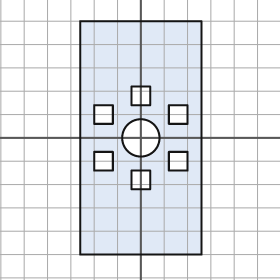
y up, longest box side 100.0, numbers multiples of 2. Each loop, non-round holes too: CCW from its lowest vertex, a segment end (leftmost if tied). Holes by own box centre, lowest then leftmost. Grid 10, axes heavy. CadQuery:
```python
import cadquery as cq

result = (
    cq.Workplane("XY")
    .moveTo(-26.0, -50.0)
    .lineTo(26.0, -50.0)
    .lineTo(26.0, 50.0)
    .lineTo(-26.0, 50.0)
    .close()
    .moveTo(-4.0, -22.0)
    .lineTo(4.0, -22.0)
    .lineTo(4.0, -14.0)
    .lineTo(-4.0, -14.0)
    .close()
    .moveTo(-20.0, -14.0)
    .lineTo(-12.0, -14.0)
    .lineTo(-12.0, -6.0)
    .lineTo(-20.0, -6.0)
    .close()
    .moveTo(12.0, -14.0)
    .lineTo(20.0, -14.0)
    .lineTo(20.0, -6.0)
    .lineTo(12.0, -6.0)
    .close()
    .moveTo(0.0, 0.0)
    .circle(8.0)
    .moveTo(-20.0, 6.0)
    .lineTo(-12.0, 6.0)
    .lineTo(-12.0, 14.0)
    .lineTo(-20.0, 14.0)
    .close()
    .moveTo(12.0, 6.0)
    .lineTo(20.0, 6.0)
    .lineTo(20.0, 14.0)
    .lineTo(12.0, 14.0)
    .close()
    .moveTo(-4.0, 14.0)
    .lineTo(4.0, 14.0)
    .lineTo(4.0, 22.0)
    .lineTo(-4.0, 22.0)
    .close()
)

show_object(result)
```